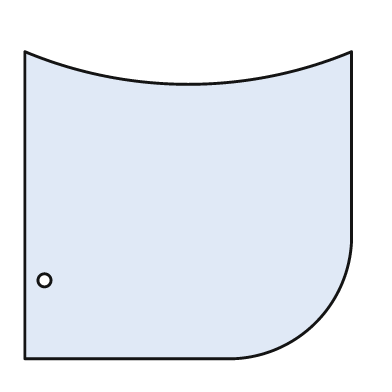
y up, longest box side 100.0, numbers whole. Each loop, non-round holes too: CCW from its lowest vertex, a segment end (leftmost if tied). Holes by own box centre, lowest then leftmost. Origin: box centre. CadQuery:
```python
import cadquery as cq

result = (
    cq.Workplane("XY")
    .moveTo(-50.0, -47.0)
    .lineTo(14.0, -47.0)
    .threePointArc((39.0, -36.0), (50.0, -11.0))
    .lineTo(50.0, 47.0)
    .threePointArc((0.0, 37.0), (-50.0, 47.0))
    .close()
    .moveTo(-44.0, -23.0)
    .circle(2.0)
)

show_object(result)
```